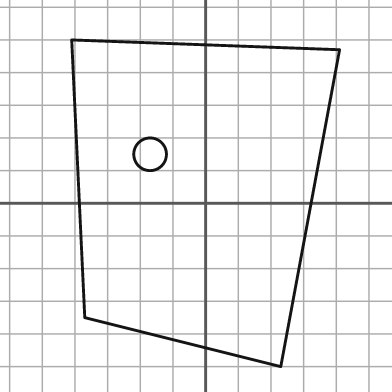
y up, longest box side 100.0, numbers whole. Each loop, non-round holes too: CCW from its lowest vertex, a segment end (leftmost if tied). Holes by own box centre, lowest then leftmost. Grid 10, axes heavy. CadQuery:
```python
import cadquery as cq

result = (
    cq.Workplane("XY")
    .moveTo(23.0, -50.0)
    .lineTo(41.0, 47.0)
    .lineTo(-41.0, 50.0)
    .lineTo(-37.0, -35.0)
    .close()
    .moveTo(-17.0, 15.0)
    .circle(5.0)
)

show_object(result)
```